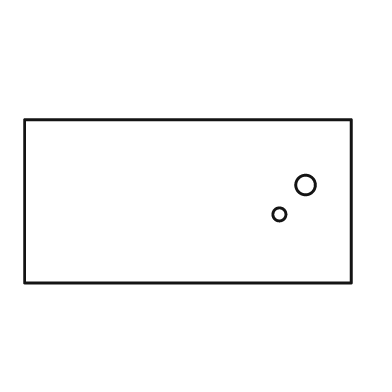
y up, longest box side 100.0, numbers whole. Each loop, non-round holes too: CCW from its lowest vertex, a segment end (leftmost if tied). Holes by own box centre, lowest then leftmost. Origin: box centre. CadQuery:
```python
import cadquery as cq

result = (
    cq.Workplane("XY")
    .moveTo(-50.0, -25.0)
    .lineTo(50.0, -25.0)
    .lineTo(50.0, 25.0)
    .lineTo(-50.0, 25.0)
    .close()
    .moveTo(28.0, -4.0)
    .circle(2.0)
    .moveTo(36.0, 5.0)
    .circle(3.0)
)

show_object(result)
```